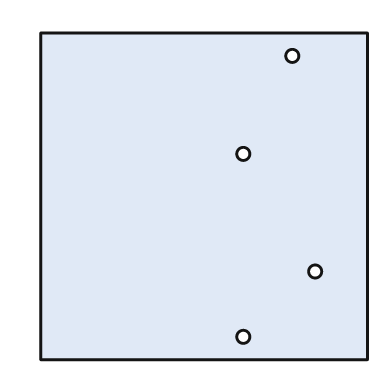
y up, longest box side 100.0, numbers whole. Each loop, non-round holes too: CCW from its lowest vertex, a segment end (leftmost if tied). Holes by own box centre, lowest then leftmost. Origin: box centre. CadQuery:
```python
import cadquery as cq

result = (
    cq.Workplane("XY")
    .moveTo(-50.0, -50.0)
    .lineTo(50.0, -50.0)
    .lineTo(50.0, 50.0)
    .lineTo(-50.0, 50.0)
    .close()
    .moveTo(12.0, -43.0)
    .circle(2.0)
    .moveTo(34.0, -23.0)
    .circle(2.0)
    .moveTo(12.0, 13.0)
    .circle(2.0)
    .moveTo(27.0, 43.0)
    .circle(2.0)
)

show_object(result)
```